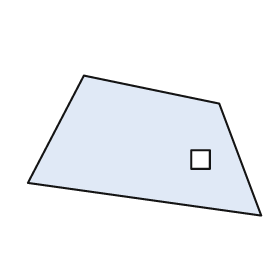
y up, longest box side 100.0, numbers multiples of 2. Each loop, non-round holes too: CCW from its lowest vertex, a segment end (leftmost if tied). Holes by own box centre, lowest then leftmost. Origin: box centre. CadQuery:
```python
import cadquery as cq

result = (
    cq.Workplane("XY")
    .moveTo(50.0, -30.0)
    .lineTo(32.0, 18.0)
    .lineTo(-26.0, 30.0)
    .lineTo(-50.0, -16.0)
    .close()
    .moveTo(20.0, -10.0)
    .lineTo(28.0, -10.0)
    .lineTo(28.0, -2.0)
    .lineTo(20.0, -2.0)
    .close()
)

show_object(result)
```